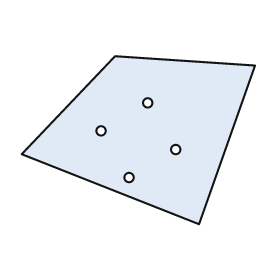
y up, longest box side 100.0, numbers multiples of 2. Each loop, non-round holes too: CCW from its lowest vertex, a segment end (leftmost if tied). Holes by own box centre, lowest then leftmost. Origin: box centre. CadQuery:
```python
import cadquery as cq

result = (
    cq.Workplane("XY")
    .moveTo(26.0, -36.0)
    .lineTo(50.0, 32.0)
    .lineTo(-10.0, 36.0)
    .lineTo(-50.0, -6.0)
    .close()
    .moveTo(-4.0, -16.0)
    .circle(2.0)
    .moveTo(16.0, -4.0)
    .circle(2.0)
    .moveTo(-16.0, 4.0)
    .circle(2.0)
    .moveTo(4.0, 16.0)
    .circle(2.0)
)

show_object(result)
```